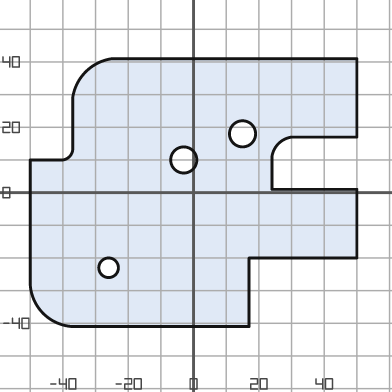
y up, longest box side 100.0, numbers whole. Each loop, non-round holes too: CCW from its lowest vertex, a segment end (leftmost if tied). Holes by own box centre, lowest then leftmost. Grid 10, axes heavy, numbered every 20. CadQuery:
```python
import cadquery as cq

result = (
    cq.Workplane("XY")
    .moveTo(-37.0, -41.0)
    .lineTo(17.0, -41.0)
    .lineTo(17.0, -20.0)
    .lineTo(50.0, -20.0)
    .lineTo(50.0, 1.0)
    .lineTo(24.0, 1.0)
    .lineTo(24.0, 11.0)
    .threePointArc((26.0, 15.0), (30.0, 17.0))
    .lineTo(50.0, 17.0)
    .lineTo(50.0, 41.0)
    .lineTo(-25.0, 41.0)
    .threePointArc((-33.0, 37.0), (-37.0, 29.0))
    .lineTo(-37.0, 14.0)
    .threePointArc((-38.0, 11.0), (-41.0, 10.0))
    .lineTo(-50.0, 10.0)
    .lineTo(-50.0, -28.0)
    .threePointArc((-46.0, -37.0), (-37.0, -41.0))
    .close()
    .moveTo(-26.0, -23.0)
    .circle(3.0)
    .moveTo(-3.0, 10.0)
    .circle(4.0)
    .moveTo(15.0, 18.0)
    .circle(4.0)
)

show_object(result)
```